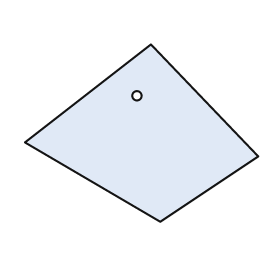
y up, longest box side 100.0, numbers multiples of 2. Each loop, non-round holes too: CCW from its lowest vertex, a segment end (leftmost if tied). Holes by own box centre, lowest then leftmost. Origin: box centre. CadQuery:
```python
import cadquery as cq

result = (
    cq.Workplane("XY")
    .moveTo(8.0, -38.0)
    .lineTo(50.0, -10.0)
    .lineTo(4.0, 38.0)
    .lineTo(-50.0, -4.0)
    .close()
    .moveTo(-2.0, 16.0)
    .circle(2.0)
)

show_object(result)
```